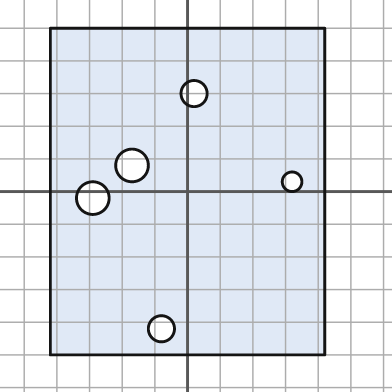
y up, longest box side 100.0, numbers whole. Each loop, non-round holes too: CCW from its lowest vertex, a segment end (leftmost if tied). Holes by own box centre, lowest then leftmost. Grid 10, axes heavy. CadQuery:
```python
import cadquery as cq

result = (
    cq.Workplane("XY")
    .moveTo(-42.0, -50.0)
    .lineTo(42.0, -50.0)
    .lineTo(42.0, 50.0)
    .lineTo(-42.0, 50.0)
    .close()
    .moveTo(-8.0, -42.0)
    .circle(4.0)
    .moveTo(-29.0, -2.0)
    .circle(5.0)
    .moveTo(32.0, 3.0)
    .circle(3.0)
    .moveTo(-17.0, 8.0)
    .circle(5.0)
    .moveTo(2.0, 30.0)
    .circle(4.0)
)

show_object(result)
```